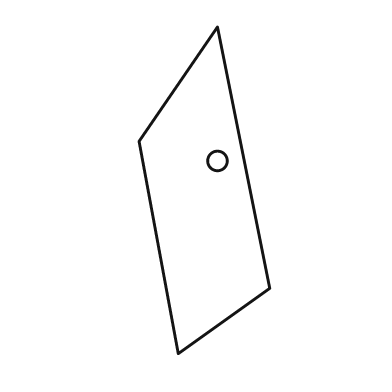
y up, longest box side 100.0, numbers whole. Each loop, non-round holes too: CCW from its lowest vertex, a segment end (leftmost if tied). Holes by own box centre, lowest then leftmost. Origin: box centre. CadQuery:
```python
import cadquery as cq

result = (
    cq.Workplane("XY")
    .moveTo(-8.0, -50.0)
    .lineTo(20.0, -30.0)
    .lineTo(4.0, 50.0)
    .lineTo(-20.0, 15.0)
    .close()
    .moveTo(4.0, 9.0)
    .circle(3.0)
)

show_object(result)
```